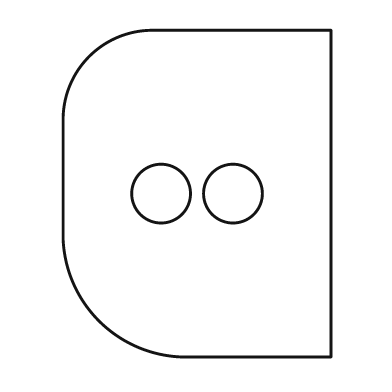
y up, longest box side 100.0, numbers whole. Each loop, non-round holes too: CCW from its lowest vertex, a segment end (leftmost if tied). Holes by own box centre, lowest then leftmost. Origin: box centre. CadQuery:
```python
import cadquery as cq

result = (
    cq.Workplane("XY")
    .moveTo(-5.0, -50.0)
    .lineTo(41.0, -50.0)
    .lineTo(41.0, 50.0)
    .lineTo(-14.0, 50.0)
    .threePointArc((-33.0, 42.0), (-41.0, 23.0))
    .lineTo(-41.0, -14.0)
    .threePointArc((-30.0, -39.0), (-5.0, -50.0))
    .close()
    .moveTo(-11.0, 0.0)
    .circle(9.0)
    .moveTo(11.0, 0.0)
    .circle(9.0)
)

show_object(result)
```